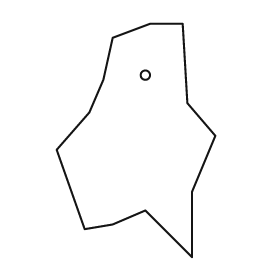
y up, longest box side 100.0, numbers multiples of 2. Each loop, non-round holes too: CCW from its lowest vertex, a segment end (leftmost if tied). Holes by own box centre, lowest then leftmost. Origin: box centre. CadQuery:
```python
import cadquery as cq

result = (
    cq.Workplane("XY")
    .moveTo(24.0, -50.0)
    .lineTo(24.0, -22.0)
    .lineTo(34.0, 2.0)
    .lineTo(22.0, 16.0)
    .lineTo(20.0, 50.0)
    .lineTo(6.0, 50.0)
    .lineTo(-10.0, 44.0)
    .lineTo(-14.0, 26.0)
    .lineTo(-20.0, 12.0)
    .lineTo(-34.0, -4.0)
    .lineTo(-22.0, -38.0)
    .lineTo(-10.0, -36.0)
    .lineTo(4.0, -30.0)
    .close()
    .moveTo(4.0, 28.0)
    .circle(2.0)
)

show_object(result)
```